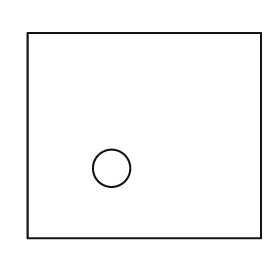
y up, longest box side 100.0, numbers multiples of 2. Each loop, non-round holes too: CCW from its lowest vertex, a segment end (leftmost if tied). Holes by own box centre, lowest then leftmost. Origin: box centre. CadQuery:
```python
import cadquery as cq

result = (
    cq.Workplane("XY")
    .moveTo(-50.0, -44.0)
    .lineTo(50.0, -44.0)
    .lineTo(50.0, 44.0)
    .lineTo(-50.0, 44.0)
    .close()
    .moveTo(-14.0, -14.0)
    .circle(8.0)
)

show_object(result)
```